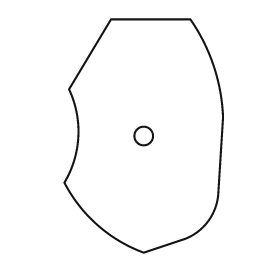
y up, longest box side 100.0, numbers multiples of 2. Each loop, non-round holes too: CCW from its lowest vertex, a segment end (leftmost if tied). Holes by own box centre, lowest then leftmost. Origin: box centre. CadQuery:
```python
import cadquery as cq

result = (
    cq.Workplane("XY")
    .moveTo(0.0, -50.0)
    .lineTo(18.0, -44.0)
    .threePointArc((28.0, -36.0), (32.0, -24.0))
    .lineTo(34.0, 8.0)
    .threePointArc((30.0, 30.0), (20.0, 50.0))
    .lineTo(-14.0, 50.0)
    .lineTo(-32.0, 20.0)
    .threePointArc((-28.0, 0.0), (-34.0, -20.0))
    .threePointArc((-20.0, -38.0), (0.0, -50.0))
    .close()
    .moveTo(0.0, 0.0)
    .circle(4.0)
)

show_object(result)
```